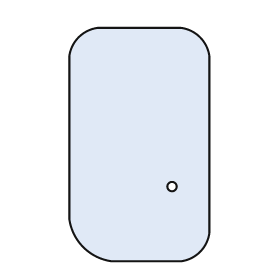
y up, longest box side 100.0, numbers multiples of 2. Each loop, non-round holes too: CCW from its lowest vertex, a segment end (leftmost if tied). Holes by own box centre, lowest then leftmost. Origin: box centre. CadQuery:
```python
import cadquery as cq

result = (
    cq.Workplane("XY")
    .moveTo(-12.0, -50.0)
    .lineTo(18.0, -50.0)
    .threePointArc((26.0, -46.0), (30.0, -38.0))
    .lineTo(30.0, 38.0)
    .threePointArc((26.0, 46.0), (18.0, 50.0))
    .lineTo(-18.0, 50.0)
    .threePointArc((-26.0, 46.0), (-30.0, 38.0))
    .lineTo(-30.0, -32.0)
    .threePointArc((-24.0, -44.0), (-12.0, -50.0))
    .close()
    .moveTo(14.0, -18.0)
    .circle(2.0)
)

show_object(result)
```